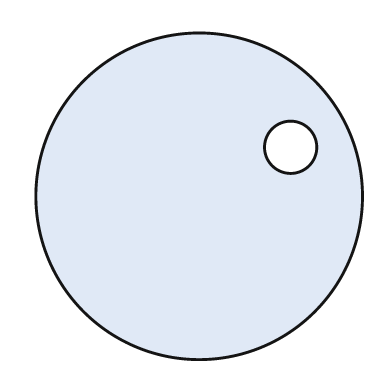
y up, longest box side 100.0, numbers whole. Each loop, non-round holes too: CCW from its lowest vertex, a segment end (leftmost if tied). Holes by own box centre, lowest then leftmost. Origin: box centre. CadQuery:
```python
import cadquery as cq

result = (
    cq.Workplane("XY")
    .moveTo(0.0, 0.0)
    .circle(50.0)
    .moveTo(28.0, 15.0)
    .circle(8.0)
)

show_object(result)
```